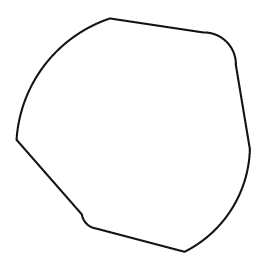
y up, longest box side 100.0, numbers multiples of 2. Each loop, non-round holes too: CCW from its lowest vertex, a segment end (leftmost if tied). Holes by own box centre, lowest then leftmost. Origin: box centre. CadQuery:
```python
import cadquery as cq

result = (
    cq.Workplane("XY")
    .moveTo(22.0, -50.0)
    .threePointArc((42.0, -32.0), (50.0, -6.0))
    .lineTo(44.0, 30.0)
    .threePointArc((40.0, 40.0), (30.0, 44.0))
    .lineTo(-10.0, 50.0)
    .threePointArc((-38.0, 30.0), (-50.0, -2.0))
    .lineTo(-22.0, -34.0)
    .threePointArc((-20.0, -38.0), (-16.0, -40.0))
    .close()
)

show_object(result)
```